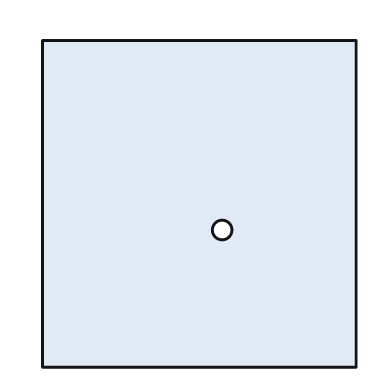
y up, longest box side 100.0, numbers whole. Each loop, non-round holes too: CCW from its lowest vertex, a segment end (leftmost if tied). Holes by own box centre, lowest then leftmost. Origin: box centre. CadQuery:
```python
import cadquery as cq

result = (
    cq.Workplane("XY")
    .moveTo(-48.0, -50.0)
    .lineTo(48.0, -50.0)
    .lineTo(48.0, 50.0)
    .lineTo(-48.0, 50.0)
    .close()
    .moveTo(7.0, -8.0)
    .circle(3.0)
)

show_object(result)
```